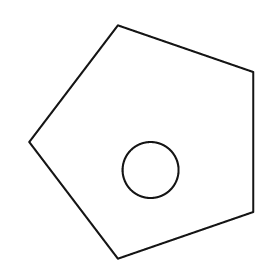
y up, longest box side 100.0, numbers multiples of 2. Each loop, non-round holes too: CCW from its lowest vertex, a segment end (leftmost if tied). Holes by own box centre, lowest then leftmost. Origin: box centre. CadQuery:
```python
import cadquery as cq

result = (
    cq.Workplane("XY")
    .moveTo(-10.0, -50.0)
    .lineTo(48.0, -30.0)
    .lineTo(48.0, 30.0)
    .lineTo(-10.0, 50.0)
    .lineTo(-48.0, 0.0)
    .close()
    .moveTo(4.0, -12.0)
    .circle(12.0)
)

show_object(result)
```